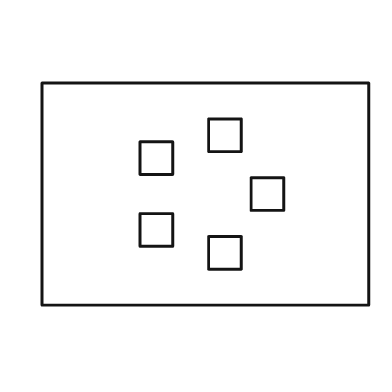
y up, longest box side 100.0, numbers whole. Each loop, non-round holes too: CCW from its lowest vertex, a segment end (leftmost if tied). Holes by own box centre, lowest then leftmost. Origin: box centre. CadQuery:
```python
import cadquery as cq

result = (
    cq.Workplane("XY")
    .moveTo(-50.0, -34.0)
    .lineTo(50.0, -34.0)
    .lineTo(50.0, 34.0)
    .lineTo(-50.0, 34.0)
    .close()
    .moveTo(1.0, -23.0)
    .lineTo(11.0, -23.0)
    .lineTo(11.0, -13.0)
    .lineTo(1.0, -13.0)
    .close()
    .moveTo(-20.0, -16.0)
    .lineTo(-10.0, -16.0)
    .lineTo(-10.0, -6.0)
    .lineTo(-20.0, -6.0)
    .close()
    .moveTo(14.0, -5.0)
    .lineTo(24.0, -5.0)
    .lineTo(24.0, 5.0)
    .lineTo(14.0, 5.0)
    .close()
    .moveTo(-20.0, 6.0)
    .lineTo(-10.0, 6.0)
    .lineTo(-10.0, 16.0)
    .lineTo(-20.0, 16.0)
    .close()
    .moveTo(1.0, 13.0)
    .lineTo(11.0, 13.0)
    .lineTo(11.0, 23.0)
    .lineTo(1.0, 23.0)
    .close()
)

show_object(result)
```